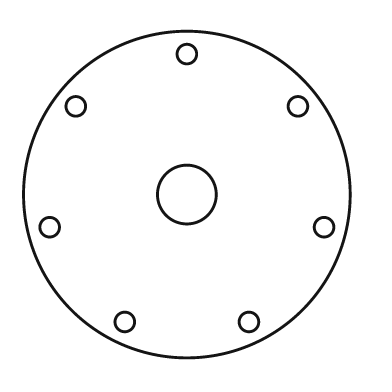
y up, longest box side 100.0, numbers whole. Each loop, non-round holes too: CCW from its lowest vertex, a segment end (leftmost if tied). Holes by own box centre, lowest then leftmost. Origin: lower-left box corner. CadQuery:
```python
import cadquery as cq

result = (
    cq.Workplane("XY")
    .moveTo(50.0, 50.0)
    .circle(50.0)
    .moveTo(31.0, 11.0)
    .circle(3.0)
    .moveTo(69.0, 11.0)
    .circle(3.0)
    .moveTo(8.0, 40.0)
    .circle(3.0)
    .moveTo(92.0, 40.0)
    .circle(3.0)
    .moveTo(50.0, 50.0)
    .circle(9.0)
    .moveTo(16.0, 77.0)
    .circle(3.0)
    .moveTo(84.0, 77.0)
    .circle(3.0)
    .moveTo(50.0, 93.0)
    .circle(3.0)
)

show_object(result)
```